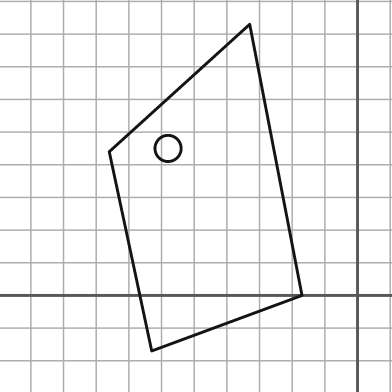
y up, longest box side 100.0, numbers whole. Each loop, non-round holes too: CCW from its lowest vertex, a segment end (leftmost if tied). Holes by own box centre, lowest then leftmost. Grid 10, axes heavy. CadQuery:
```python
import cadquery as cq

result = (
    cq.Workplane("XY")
    .moveTo(-63.0, -17.0)
    .lineTo(-17.0, 0.0)
    .lineTo(-33.0, 83.0)
    .lineTo(-76.0, 44.0)
    .close()
    .moveTo(-58.0, 45.0)
    .circle(4.0)
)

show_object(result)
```